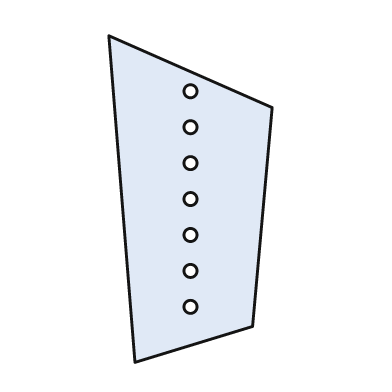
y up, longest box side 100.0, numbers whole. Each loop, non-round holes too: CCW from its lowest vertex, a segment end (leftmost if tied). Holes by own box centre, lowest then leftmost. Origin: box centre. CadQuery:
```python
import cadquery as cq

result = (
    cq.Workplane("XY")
    .moveTo(-17.0, -50.0)
    .lineTo(19.0, -39.0)
    .lineTo(25.0, 28.0)
    .lineTo(-25.0, 50.0)
    .close()
    .moveTo(0.0, -33.0)
    .circle(2.0)
    .moveTo(0.0, -22.0)
    .circle(2.0)
    .moveTo(0.0, -11.0)
    .circle(2.0)
    .moveTo(0.0, 0.0)
    .circle(2.0)
    .moveTo(0.0, 11.0)
    .circle(2.0)
    .moveTo(0.0, 22.0)
    .circle(2.0)
    .moveTo(0.0, 33.0)
    .circle(2.0)
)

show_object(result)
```